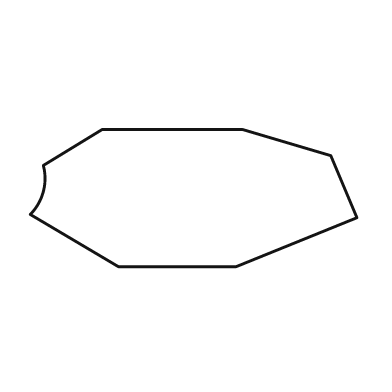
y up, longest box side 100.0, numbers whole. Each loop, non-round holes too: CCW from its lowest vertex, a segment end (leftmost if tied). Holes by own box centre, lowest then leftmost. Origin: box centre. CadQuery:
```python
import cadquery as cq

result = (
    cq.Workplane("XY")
    .moveTo(-23.0, -21.0)
    .lineTo(13.0, -21.0)
    .lineTo(50.0, -6.0)
    .lineTo(42.0, 13.0)
    .lineTo(15.0, 21.0)
    .lineTo(-28.0, 21.0)
    .lineTo(-46.0, 10.0)
    .threePointArc((-46.0, 2.0), (-50.0, -5.0))
    .close()
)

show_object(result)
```